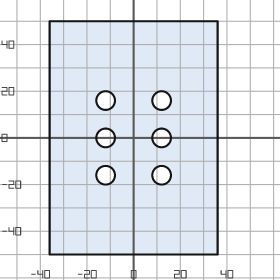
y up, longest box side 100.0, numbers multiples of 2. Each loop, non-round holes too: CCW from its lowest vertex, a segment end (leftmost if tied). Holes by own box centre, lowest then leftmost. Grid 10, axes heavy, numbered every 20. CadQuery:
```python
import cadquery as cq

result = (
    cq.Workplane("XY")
    .moveTo(-36.0, -50.0)
    .lineTo(36.0, -50.0)
    .lineTo(36.0, 50.0)
    .lineTo(-36.0, 50.0)
    .close()
    .moveTo(-12.0, -16.0)
    .circle(4.0)
    .moveTo(12.0, -16.0)
    .circle(4.0)
    .moveTo(-12.0, 0.0)
    .circle(4.0)
    .moveTo(12.0, 0.0)
    .circle(4.0)
    .moveTo(-12.0, 16.0)
    .circle(4.0)
    .moveTo(12.0, 16.0)
    .circle(4.0)
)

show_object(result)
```